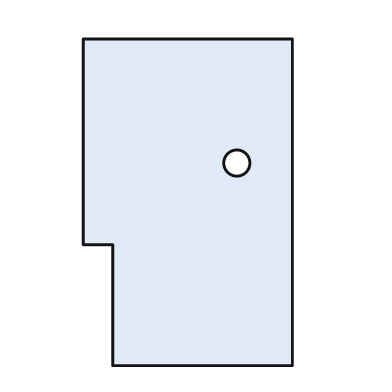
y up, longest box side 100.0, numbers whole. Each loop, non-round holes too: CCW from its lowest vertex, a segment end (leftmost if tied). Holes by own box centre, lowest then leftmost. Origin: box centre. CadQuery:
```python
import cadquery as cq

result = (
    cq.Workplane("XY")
    .moveTo(-23.0, -50.0)
    .lineTo(32.0, -50.0)
    .lineTo(32.0, 50.0)
    .lineTo(-32.0, 50.0)
    .lineTo(-32.0, -13.0)
    .lineTo(-23.0, -13.0)
    .close()
    .moveTo(15.0, 12.0)
    .circle(4.0)
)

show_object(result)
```